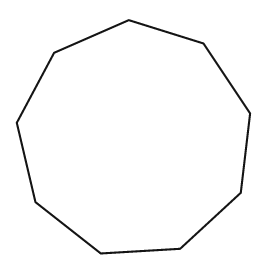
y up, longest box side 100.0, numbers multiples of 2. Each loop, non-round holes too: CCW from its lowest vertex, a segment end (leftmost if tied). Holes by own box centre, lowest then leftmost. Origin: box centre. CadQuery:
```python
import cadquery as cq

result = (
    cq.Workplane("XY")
    .moveTo(-14.0, -50.0)
    .lineTo(20.0, -48.0)
    .lineTo(46.0, -24.0)
    .lineTo(50.0, 10.0)
    .lineTo(30.0, 40.0)
    .lineTo(-2.0, 50.0)
    .lineTo(-34.0, 36.0)
    .lineTo(-50.0, 6.0)
    .lineTo(-42.0, -28.0)
    .close()
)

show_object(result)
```